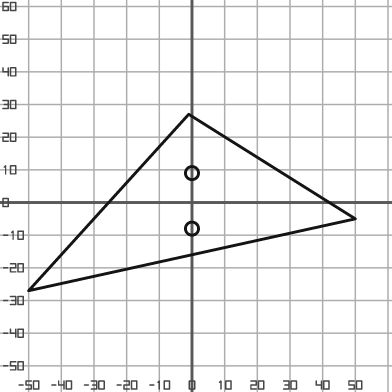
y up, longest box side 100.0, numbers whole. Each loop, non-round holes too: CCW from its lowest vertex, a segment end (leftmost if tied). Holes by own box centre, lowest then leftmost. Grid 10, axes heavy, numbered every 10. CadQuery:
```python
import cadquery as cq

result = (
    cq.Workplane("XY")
    .moveTo(-50.0, -27.0)
    .lineTo(50.0, -5.0)
    .lineTo(-1.0, 27.0)
    .close()
    .moveTo(0.0, -8.0)
    .circle(2.0)
    .moveTo(0.0, 9.0)
    .circle(2.0)
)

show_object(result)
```